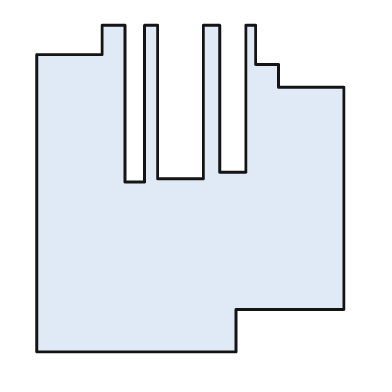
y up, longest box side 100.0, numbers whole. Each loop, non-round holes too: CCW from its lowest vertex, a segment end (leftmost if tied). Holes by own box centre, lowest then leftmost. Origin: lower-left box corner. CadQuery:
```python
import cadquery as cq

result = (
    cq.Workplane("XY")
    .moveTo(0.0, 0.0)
    .lineTo(61.0, 0.0)
    .lineTo(61.0, 13.0)
    .lineTo(94.0, 13.0)
    .lineTo(94.0, 81.0)
    .lineTo(74.0, 81.0)
    .lineTo(74.0, 88.0)
    .lineTo(67.0, 88.0)
    .lineTo(67.0, 100.0)
    .lineTo(64.0, 100.0)
    .lineTo(64.0, 55.0)
    .lineTo(56.0, 55.0)
    .lineTo(56.0, 100.0)
    .lineTo(51.0, 100.0)
    .lineTo(51.0, 53.0)
    .lineTo(37.0, 53.0)
    .lineTo(37.0, 100.0)
    .lineTo(33.0, 100.0)
    .lineTo(33.0, 52.0)
    .lineTo(27.0, 52.0)
    .lineTo(27.0, 100.0)
    .lineTo(20.0, 100.0)
    .lineTo(20.0, 91.0)
    .lineTo(0.0, 91.0)
    .close()
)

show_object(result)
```